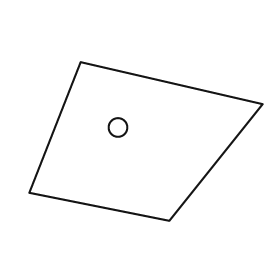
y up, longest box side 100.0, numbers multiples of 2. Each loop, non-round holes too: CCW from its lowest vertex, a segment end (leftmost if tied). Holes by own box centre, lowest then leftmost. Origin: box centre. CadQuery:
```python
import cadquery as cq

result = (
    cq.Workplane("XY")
    .moveTo(10.0, -34.0)
    .lineTo(50.0, 16.0)
    .lineTo(-28.0, 34.0)
    .lineTo(-50.0, -22.0)
    .close()
    .moveTo(-12.0, 6.0)
    .circle(4.0)
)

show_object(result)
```